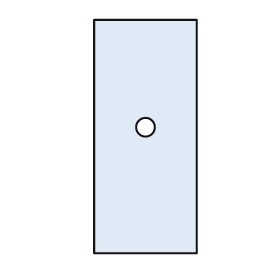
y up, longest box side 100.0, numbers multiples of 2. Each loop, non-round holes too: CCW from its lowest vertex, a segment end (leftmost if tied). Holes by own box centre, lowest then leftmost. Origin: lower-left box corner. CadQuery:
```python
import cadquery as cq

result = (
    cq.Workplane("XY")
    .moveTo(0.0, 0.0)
    .lineTo(44.0, 0.0)
    .lineTo(44.0, 100.0)
    .lineTo(0.0, 100.0)
    .close()
    .moveTo(22.0, 54.0)
    .circle(4.0)
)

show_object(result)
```